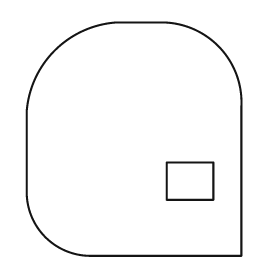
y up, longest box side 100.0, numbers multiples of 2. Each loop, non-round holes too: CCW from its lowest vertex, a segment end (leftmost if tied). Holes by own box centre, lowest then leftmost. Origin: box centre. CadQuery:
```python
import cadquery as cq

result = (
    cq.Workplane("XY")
    .moveTo(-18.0, -50.0)
    .lineTo(46.0, -50.0)
    .lineTo(46.0, 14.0)
    .threePointArc((36.0, 40.0), (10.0, 50.0))
    .lineTo(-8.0, 50.0)
    .threePointArc((-34.0, 38.0), (-46.0, 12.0))
    .lineTo(-46.0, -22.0)
    .threePointArc((-38.0, -42.0), (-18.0, -50.0))
    .close()
    .moveTo(14.0, -26.0)
    .lineTo(34.0, -26.0)
    .lineTo(34.0, -10.0)
    .lineTo(14.0, -10.0)
    .close()
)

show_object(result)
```